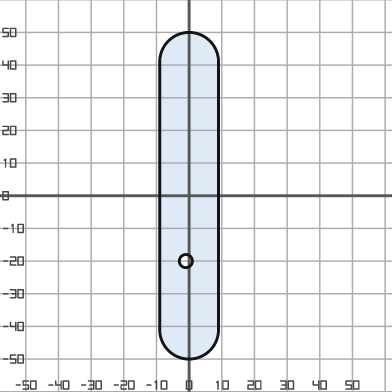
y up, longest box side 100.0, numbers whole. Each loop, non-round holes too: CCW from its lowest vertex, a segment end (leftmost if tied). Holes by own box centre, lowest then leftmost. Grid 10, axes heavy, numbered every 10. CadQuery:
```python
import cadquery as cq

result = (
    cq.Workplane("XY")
    .moveTo(-9.0, -41.0)
    .threePointArc((0.0, -50.0), (9.0, -41.0))
    .lineTo(9.0, 41.0)
    .threePointArc((0.0, 50.0), (-9.0, 41.0))
    .close()
    .moveTo(-1.0, -20.0)
    .circle(2.0)
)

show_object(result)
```